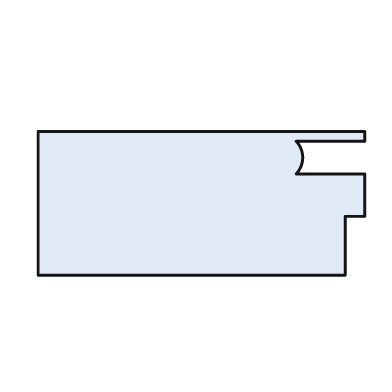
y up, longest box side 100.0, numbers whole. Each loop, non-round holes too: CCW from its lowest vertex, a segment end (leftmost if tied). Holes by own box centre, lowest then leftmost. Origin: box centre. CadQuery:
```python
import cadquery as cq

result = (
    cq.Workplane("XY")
    .moveTo(-50.0, -22.0)
    .lineTo(44.0, -22.0)
    .lineTo(44.0, -4.0)
    .lineTo(50.0, -4.0)
    .lineTo(50.0, 9.0)
    .lineTo(29.0, 9.0)
    .threePointArc((31.0, 14.0), (29.0, 19.0))
    .lineTo(50.0, 19.0)
    .lineTo(50.0, 22.0)
    .lineTo(-50.0, 22.0)
    .close()
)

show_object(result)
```